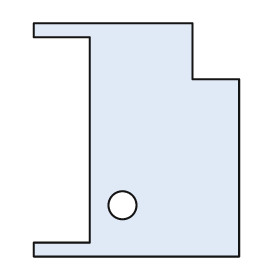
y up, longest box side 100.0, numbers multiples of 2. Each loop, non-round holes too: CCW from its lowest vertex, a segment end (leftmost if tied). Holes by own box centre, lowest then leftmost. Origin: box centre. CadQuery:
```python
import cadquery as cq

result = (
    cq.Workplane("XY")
    .moveTo(-44.0, -50.0)
    .lineTo(44.0, -50.0)
    .lineTo(44.0, 26.0)
    .lineTo(24.0, 26.0)
    .lineTo(24.0, 50.0)
    .lineTo(-44.0, 50.0)
    .lineTo(-44.0, 44.0)
    .lineTo(-20.0, 44.0)
    .lineTo(-20.0, -44.0)
    .lineTo(-44.0, -44.0)
    .close()
    .moveTo(-6.0, -28.0)
    .circle(6.0)
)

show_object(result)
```